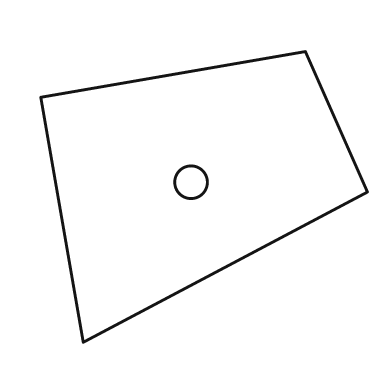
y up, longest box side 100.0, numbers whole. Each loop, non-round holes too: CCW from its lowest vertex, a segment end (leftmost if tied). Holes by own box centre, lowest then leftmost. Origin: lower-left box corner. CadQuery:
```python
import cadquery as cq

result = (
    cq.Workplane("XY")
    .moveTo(13.0, 0.0)
    .lineTo(100.0, 46.0)
    .lineTo(81.0, 89.0)
    .lineTo(0.0, 75.0)
    .close()
    .moveTo(46.0, 49.0)
    .circle(5.0)
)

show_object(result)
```